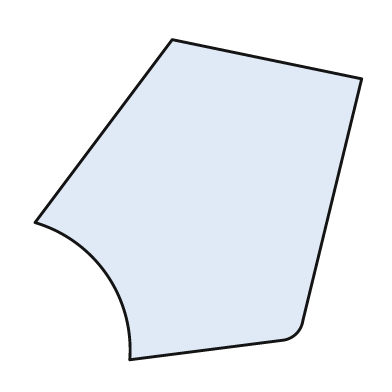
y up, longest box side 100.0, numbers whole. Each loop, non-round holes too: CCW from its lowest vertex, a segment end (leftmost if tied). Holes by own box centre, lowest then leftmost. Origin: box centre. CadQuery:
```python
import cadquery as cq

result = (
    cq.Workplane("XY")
    .moveTo(-21.0, -49.0)
    .lineTo(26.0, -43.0)
    .threePointArc((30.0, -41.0), (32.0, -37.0))
    .lineTo(50.0, 37.0)
    .lineTo(-8.0, 49.0)
    .lineTo(-50.0, -7.0)
    .threePointArc((-28.0, -23.0), (-21.0, -49.0))
    .close()
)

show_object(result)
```